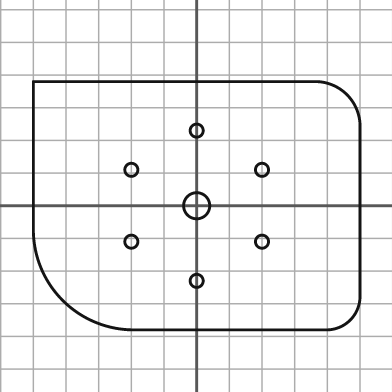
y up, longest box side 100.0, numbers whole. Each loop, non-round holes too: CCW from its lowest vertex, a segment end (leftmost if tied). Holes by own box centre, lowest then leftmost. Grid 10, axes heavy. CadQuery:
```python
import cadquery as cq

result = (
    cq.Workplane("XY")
    .moveTo(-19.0, -38.0)
    .lineTo(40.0, -38.0)
    .threePointArc((47.0, -35.0), (50.0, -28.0))
    .lineTo(50.0, 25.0)
    .threePointArc((46.0, 34.0), (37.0, 38.0))
    .lineTo(-50.0, 38.0)
    .lineTo(-50.0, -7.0)
    .threePointArc((-41.0, -29.0), (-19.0, -38.0))
    .close()
    .moveTo(0.0, -23.0)
    .circle(2.0)
    .moveTo(-20.0, -11.0)
    .circle(2.0)
    .moveTo(20.0, -11.0)
    .circle(2.0)
    .moveTo(0.0, 0.0)
    .circle(4.0)
    .moveTo(-20.0, 11.0)
    .circle(2.0)
    .moveTo(20.0, 11.0)
    .circle(2.0)
    .moveTo(0.0, 23.0)
    .circle(2.0)
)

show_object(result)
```